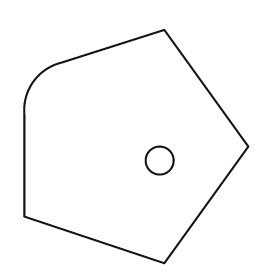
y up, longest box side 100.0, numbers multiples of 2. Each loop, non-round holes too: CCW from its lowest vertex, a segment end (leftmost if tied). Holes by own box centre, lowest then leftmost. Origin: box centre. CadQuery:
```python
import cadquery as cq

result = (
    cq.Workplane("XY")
    .moveTo(12.0, -50.0)
    .lineTo(48.0, 0.0)
    .lineTo(12.0, 50.0)
    .lineTo(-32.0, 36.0)
    .threePointArc((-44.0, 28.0), (-48.0, 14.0))
    .lineTo(-48.0, -30.0)
    .close()
    .moveTo(10.0, -6.0)
    .circle(6.0)
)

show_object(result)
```